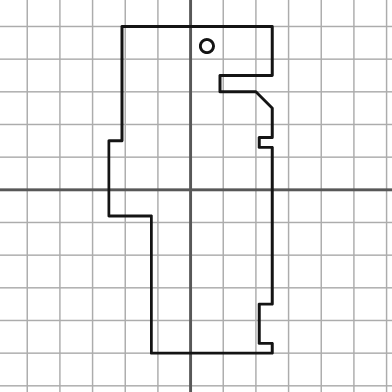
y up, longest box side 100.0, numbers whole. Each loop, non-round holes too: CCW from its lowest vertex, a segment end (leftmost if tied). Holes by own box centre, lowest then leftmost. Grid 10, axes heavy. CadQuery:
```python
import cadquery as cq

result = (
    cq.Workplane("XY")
    .moveTo(-12.0, -50.0)
    .lineTo(25.0, -50.0)
    .lineTo(25.0, -47.0)
    .lineTo(21.0, -47.0)
    .lineTo(21.0, -35.0)
    .lineTo(25.0, -35.0)
    .lineTo(25.0, 13.0)
    .lineTo(21.0, 13.0)
    .lineTo(21.0, 16.0)
    .lineTo(25.0, 16.0)
    .lineTo(25.0, 25.0)
    .lineTo(20.0, 30.0)
    .lineTo(9.0, 30.0)
    .lineTo(9.0, 35.0)
    .lineTo(25.0, 35.0)
    .lineTo(25.0, 50.0)
    .lineTo(-21.0, 50.0)
    .lineTo(-21.0, 15.0)
    .lineTo(-25.0, 15.0)
    .lineTo(-25.0, -8.0)
    .lineTo(-12.0, -8.0)
    .close()
    .moveTo(5.0, 44.0)
    .circle(2.0)
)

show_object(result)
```